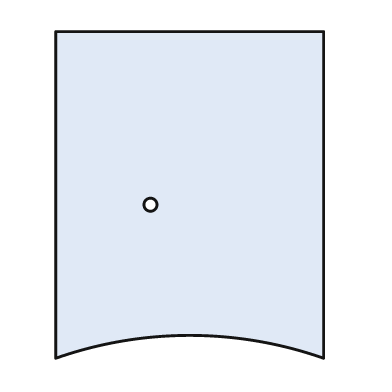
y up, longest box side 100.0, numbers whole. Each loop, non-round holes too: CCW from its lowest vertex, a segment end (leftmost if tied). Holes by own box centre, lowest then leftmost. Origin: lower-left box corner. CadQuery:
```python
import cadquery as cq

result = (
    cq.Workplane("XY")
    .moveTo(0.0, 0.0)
    .threePointArc((41.0, 7.0), (82.0, 0.0))
    .lineTo(82.0, 100.0)
    .lineTo(0.0, 100.0)
    .close()
    .moveTo(29.0, 47.0)
    .circle(2.0)
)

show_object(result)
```